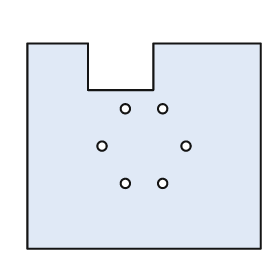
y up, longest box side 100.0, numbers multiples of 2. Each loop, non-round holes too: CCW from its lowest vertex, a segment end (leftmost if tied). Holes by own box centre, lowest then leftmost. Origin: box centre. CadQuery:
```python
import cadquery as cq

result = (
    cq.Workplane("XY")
    .moveTo(-50.0, -44.0)
    .lineTo(50.0, -44.0)
    .lineTo(50.0, 44.0)
    .lineTo(4.0, 44.0)
    .lineTo(4.0, 24.0)
    .lineTo(-24.0, 24.0)
    .lineTo(-24.0, 44.0)
    .lineTo(-50.0, 44.0)
    .close()
    .moveTo(-8.0, -16.0)
    .circle(2.0)
    .moveTo(8.0, -16.0)
    .circle(2.0)
    .moveTo(-18.0, 0.0)
    .circle(2.0)
    .moveTo(18.0, 0.0)
    .circle(2.0)
    .moveTo(-8.0, 16.0)
    .circle(2.0)
    .moveTo(8.0, 16.0)
    .circle(2.0)
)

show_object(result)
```